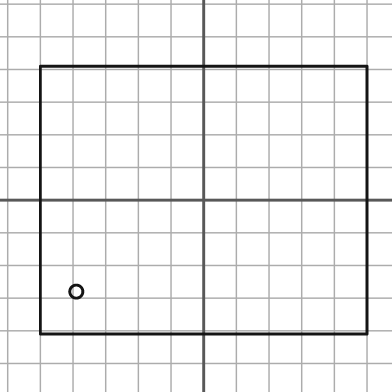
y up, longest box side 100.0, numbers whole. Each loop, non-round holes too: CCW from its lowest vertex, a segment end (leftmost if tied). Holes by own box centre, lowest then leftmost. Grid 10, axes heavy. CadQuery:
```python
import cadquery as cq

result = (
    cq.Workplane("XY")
    .moveTo(-50.0, -41.0)
    .lineTo(50.0, -41.0)
    .lineTo(50.0, 41.0)
    .lineTo(-50.0, 41.0)
    .close()
    .moveTo(-39.0, -28.0)
    .circle(2.0)
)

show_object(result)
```